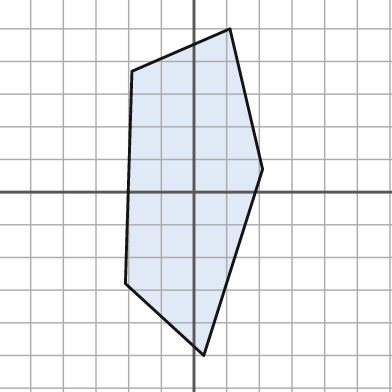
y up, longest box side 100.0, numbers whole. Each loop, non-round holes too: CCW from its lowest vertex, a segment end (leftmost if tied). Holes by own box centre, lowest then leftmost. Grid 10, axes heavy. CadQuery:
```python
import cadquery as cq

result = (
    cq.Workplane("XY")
    .moveTo(3.0, -50.0)
    .lineTo(21.0, 7.0)
    .lineTo(11.0, 50.0)
    .lineTo(-19.0, 37.0)
    .lineTo(-21.0, -28.0)
    .close()
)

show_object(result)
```